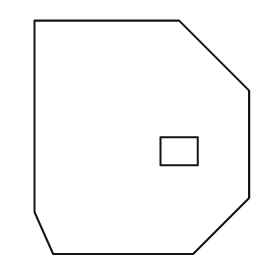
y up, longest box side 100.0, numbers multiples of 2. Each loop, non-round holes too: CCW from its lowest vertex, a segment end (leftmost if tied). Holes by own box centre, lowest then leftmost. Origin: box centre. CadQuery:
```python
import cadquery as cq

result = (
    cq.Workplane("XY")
    .moveTo(-38.0, -50.0)
    .lineTo(22.0, -50.0)
    .lineTo(46.0, -26.0)
    .lineTo(46.0, 20.0)
    .lineTo(16.0, 50.0)
    .lineTo(-46.0, 50.0)
    .lineTo(-46.0, -32.0)
    .close()
    .moveTo(8.0, -12.0)
    .lineTo(24.0, -12.0)
    .lineTo(24.0, 0.0)
    .lineTo(8.0, 0.0)
    .close()
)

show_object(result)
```